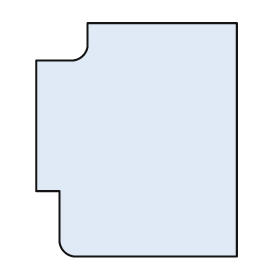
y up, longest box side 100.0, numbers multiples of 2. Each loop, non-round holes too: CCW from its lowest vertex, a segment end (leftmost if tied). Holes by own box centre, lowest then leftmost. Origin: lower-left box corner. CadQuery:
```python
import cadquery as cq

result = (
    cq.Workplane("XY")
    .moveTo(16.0, 0.0)
    .lineTo(86.0, 0.0)
    .lineTo(86.0, 100.0)
    .lineTo(22.0, 100.0)
    .lineTo(22.0, 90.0)
    .threePointArc((20.0, 86.0), (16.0, 84.0))
    .lineTo(0.0, 84.0)
    .lineTo(0.0, 28.0)
    .lineTo(10.0, 28.0)
    .lineTo(10.0, 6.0)
    .threePointArc((12.0, 2.0), (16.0, 0.0))
    .close()
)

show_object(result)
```